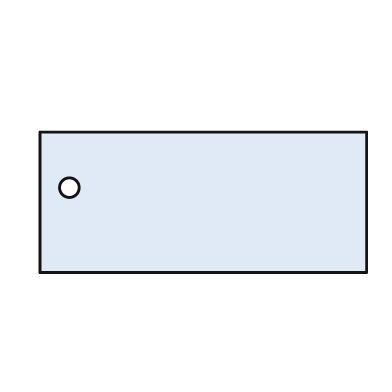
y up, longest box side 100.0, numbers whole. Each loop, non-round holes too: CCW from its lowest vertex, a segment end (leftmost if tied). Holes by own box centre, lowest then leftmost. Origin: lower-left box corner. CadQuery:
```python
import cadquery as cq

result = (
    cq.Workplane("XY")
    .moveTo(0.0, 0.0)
    .lineTo(100.0, 0.0)
    .lineTo(100.0, 43.0)
    .lineTo(0.0, 43.0)
    .close()
    .moveTo(9.0, 26.0)
    .circle(3.0)
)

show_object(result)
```